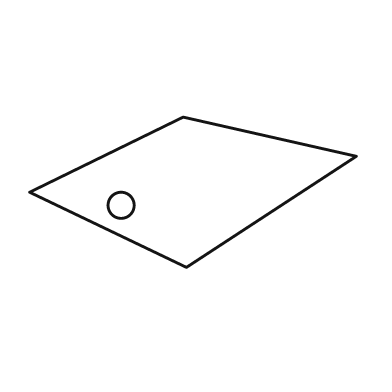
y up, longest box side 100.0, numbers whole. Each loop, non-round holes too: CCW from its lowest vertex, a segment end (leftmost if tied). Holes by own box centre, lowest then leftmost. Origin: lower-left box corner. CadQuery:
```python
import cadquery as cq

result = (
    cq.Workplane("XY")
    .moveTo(48.0, 0.0)
    .lineTo(100.0, 34.0)
    .lineTo(47.0, 46.0)
    .lineTo(0.0, 23.0)
    .close()
    .moveTo(28.0, 19.0)
    .circle(4.0)
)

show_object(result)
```